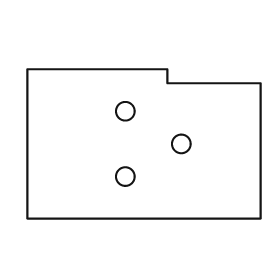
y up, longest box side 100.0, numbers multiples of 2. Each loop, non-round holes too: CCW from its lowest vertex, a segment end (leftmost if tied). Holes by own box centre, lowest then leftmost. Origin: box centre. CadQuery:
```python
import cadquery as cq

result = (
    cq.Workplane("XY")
    .moveTo(-50.0, -32.0)
    .lineTo(50.0, -32.0)
    .lineTo(50.0, 26.0)
    .lineTo(10.0, 26.0)
    .lineTo(10.0, 32.0)
    .lineTo(-50.0, 32.0)
    .close()
    .moveTo(-8.0, -14.0)
    .circle(4.0)
    .moveTo(16.0, 0.0)
    .circle(4.0)
    .moveTo(-8.0, 14.0)
    .circle(4.0)
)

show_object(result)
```